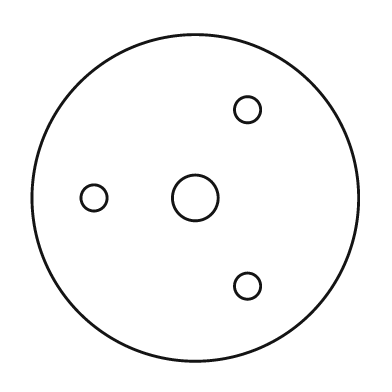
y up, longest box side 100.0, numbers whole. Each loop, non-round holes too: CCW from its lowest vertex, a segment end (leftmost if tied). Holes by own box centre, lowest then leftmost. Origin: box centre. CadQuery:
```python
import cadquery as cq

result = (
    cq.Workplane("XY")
    .moveTo(0.0, 0.0)
    .circle(50.0)
    .moveTo(16.0, -27.0)
    .circle(4.0)
    .moveTo(-31.0, 0.0)
    .circle(4.0)
    .moveTo(0.0, 0.0)
    .circle(7.0)
    .moveTo(16.0, 27.0)
    .circle(4.0)
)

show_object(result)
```